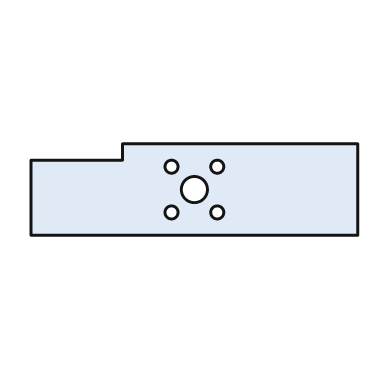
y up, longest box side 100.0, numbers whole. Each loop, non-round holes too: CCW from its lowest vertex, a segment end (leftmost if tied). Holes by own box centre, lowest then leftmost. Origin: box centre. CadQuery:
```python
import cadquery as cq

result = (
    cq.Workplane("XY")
    .moveTo(-50.0, -14.0)
    .lineTo(50.0, -14.0)
    .lineTo(50.0, 14.0)
    .lineTo(-22.0, 14.0)
    .lineTo(-22.0, 9.0)
    .lineTo(-50.0, 9.0)
    .close()
    .moveTo(-7.0, -7.0)
    .circle(2.0)
    .moveTo(7.0, -7.0)
    .circle(2.0)
    .moveTo(0.0, 0.0)
    .circle(4.0)
    .moveTo(-7.0, 7.0)
    .circle(2.0)
    .moveTo(7.0, 7.0)
    .circle(2.0)
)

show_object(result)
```